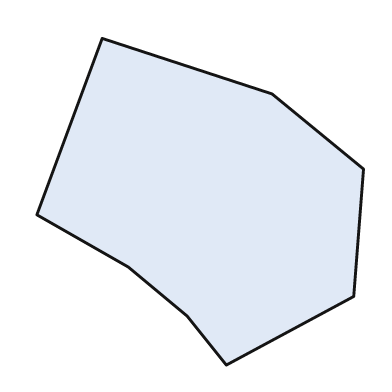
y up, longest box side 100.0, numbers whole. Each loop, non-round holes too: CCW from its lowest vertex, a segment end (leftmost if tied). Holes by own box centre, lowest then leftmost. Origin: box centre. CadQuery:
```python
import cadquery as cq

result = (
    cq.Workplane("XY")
    .moveTo(8.0, -50.0)
    .lineTo(47.0, -29.0)
    .lineTo(50.0, 10.0)
    .lineTo(22.0, 33.0)
    .lineTo(-30.0, 50.0)
    .lineTo(-50.0, -4.0)
    .lineTo(-22.0, -20.0)
    .lineTo(-4.0, -35.0)
    .close()
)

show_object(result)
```